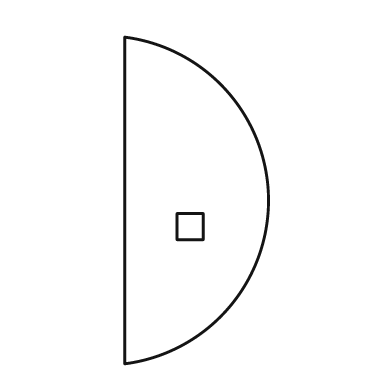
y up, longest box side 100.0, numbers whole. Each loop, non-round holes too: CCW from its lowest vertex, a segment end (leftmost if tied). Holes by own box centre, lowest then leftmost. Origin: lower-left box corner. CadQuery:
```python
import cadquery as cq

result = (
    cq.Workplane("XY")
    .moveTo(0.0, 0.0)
    .threePointArc((44.0, 50.0), (0.0, 100.0))
    .close()
    .moveTo(16.0, 38.0)
    .lineTo(24.0, 38.0)
    .lineTo(24.0, 46.0)
    .lineTo(16.0, 46.0)
    .close()
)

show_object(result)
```